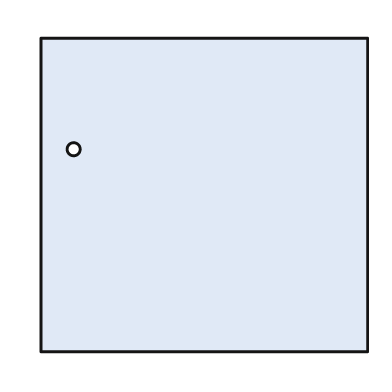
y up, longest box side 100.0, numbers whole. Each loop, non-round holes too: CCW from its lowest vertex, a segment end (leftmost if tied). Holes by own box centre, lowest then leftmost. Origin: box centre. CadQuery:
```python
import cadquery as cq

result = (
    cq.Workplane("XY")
    .moveTo(-50.0, -48.0)
    .lineTo(50.0, -48.0)
    .lineTo(50.0, 48.0)
    .lineTo(-50.0, 48.0)
    .close()
    .moveTo(-40.0, 14.0)
    .circle(2.0)
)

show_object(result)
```